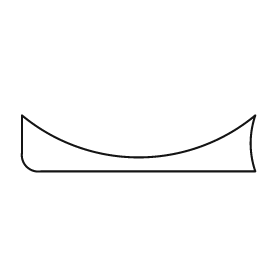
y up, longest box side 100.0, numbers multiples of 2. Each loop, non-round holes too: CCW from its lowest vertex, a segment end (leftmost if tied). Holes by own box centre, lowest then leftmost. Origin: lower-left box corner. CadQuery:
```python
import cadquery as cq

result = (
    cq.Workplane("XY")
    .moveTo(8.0, 0.0)
    .lineTo(100.0, 0.0)
    .threePointArc((98.0, 12.0), (100.0, 24.0))
    .threePointArc((50.0, 6.0), (0.0, 24.0))
    .lineTo(0.0, 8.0)
    .threePointArc((2.0, 2.0), (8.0, 0.0))
    .close()
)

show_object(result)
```